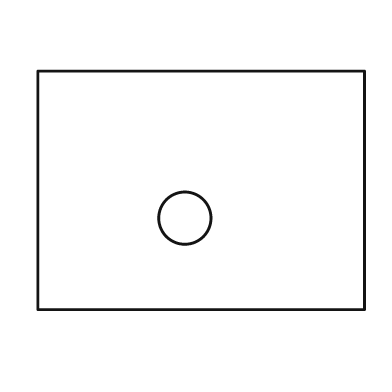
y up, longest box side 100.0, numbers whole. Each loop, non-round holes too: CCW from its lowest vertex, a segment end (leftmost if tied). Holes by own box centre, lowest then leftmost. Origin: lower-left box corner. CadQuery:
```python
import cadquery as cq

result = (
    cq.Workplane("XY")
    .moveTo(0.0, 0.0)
    .lineTo(100.0, 0.0)
    .lineTo(100.0, 73.0)
    .lineTo(0.0, 73.0)
    .close()
    .moveTo(45.0, 28.0)
    .circle(8.0)
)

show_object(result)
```